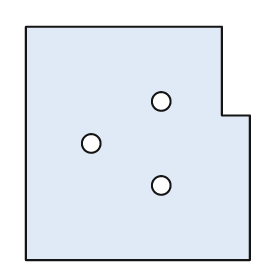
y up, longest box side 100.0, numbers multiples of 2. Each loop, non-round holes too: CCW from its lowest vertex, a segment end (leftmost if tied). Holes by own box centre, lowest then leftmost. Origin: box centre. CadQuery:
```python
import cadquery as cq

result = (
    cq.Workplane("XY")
    .moveTo(-48.0, -50.0)
    .lineTo(48.0, -50.0)
    .lineTo(48.0, 12.0)
    .lineTo(36.0, 12.0)
    .lineTo(36.0, 50.0)
    .lineTo(-48.0, 50.0)
    .close()
    .moveTo(10.0, -18.0)
    .circle(4.0)
    .moveTo(-20.0, 0.0)
    .circle(4.0)
    .moveTo(10.0, 18.0)
    .circle(4.0)
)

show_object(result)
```